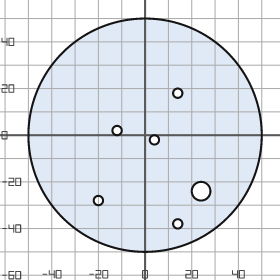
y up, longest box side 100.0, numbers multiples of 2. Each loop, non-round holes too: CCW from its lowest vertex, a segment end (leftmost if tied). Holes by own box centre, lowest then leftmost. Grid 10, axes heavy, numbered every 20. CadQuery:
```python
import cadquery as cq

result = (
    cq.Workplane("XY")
    .moveTo(0.0, 0.0)
    .circle(50.0)
    .moveTo(14.0, -38.0)
    .circle(2.0)
    .moveTo(-20.0, -28.0)
    .circle(2.0)
    .moveTo(24.0, -24.0)
    .circle(4.0)
    .moveTo(4.0, -2.0)
    .circle(2.0)
    .moveTo(-12.0, 2.0)
    .circle(2.0)
    .moveTo(14.0, 18.0)
    .circle(2.0)
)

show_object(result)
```